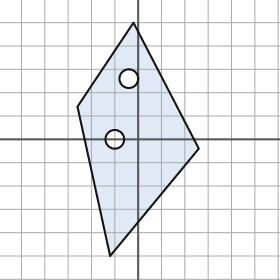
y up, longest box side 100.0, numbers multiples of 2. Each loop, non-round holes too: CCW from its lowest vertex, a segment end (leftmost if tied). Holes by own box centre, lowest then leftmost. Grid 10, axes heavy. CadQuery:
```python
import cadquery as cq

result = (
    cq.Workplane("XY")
    .moveTo(-12.0, -50.0)
    .lineTo(26.0, -4.0)
    .lineTo(-2.0, 50.0)
    .lineTo(-26.0, 14.0)
    .close()
    .moveTo(-10.0, 0.0)
    .circle(4.0)
    .moveTo(-4.0, 26.0)
    .circle(4.0)
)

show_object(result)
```